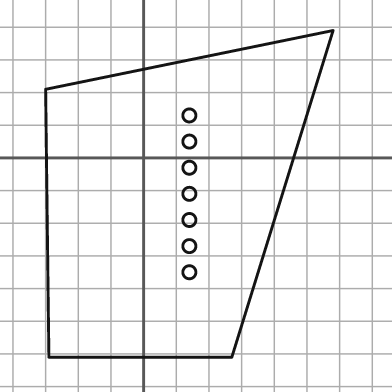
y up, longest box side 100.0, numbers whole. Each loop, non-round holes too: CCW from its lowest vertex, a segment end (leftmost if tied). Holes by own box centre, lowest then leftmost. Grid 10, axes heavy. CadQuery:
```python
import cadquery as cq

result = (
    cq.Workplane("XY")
    .moveTo(-29.0, -61.0)
    .lineTo(27.0, -61.0)
    .lineTo(58.0, 39.0)
    .lineTo(-30.0, 21.0)
    .close()
    .moveTo(14.0, -35.0)
    .circle(2.0)
    .moveTo(14.0, -27.0)
    .circle(2.0)
    .moveTo(14.0, -19.0)
    .circle(2.0)
    .moveTo(14.0, -11.0)
    .circle(2.0)
    .moveTo(14.0, -3.0)
    .circle(2.0)
    .moveTo(14.0, 5.0)
    .circle(2.0)
    .moveTo(14.0, 13.0)
    .circle(2.0)
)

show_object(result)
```